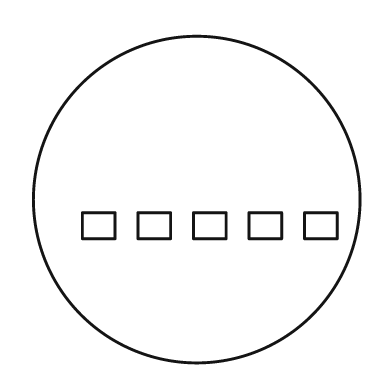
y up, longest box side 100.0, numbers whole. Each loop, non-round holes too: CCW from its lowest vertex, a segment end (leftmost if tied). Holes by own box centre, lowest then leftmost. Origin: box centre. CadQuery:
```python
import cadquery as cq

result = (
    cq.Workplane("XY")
    .moveTo(0.0, 0.0)
    .circle(50.0)
    .moveTo(-35.0, -12.0)
    .lineTo(-25.0, -12.0)
    .lineTo(-25.0, -4.0)
    .lineTo(-35.0, -4.0)
    .close()
    .moveTo(-18.0, -12.0)
    .lineTo(-8.0, -12.0)
    .lineTo(-8.0, -4.0)
    .lineTo(-18.0, -4.0)
    .close()
    .moveTo(-1.0, -12.0)
    .lineTo(9.0, -12.0)
    .lineTo(9.0, -4.0)
    .lineTo(-1.0, -4.0)
    .close()
    .moveTo(16.0, -12.0)
    .lineTo(26.0, -12.0)
    .lineTo(26.0, -4.0)
    .lineTo(16.0, -4.0)
    .close()
    .moveTo(33.0, -12.0)
    .lineTo(43.0, -12.0)
    .lineTo(43.0, -4.0)
    .lineTo(33.0, -4.0)
    .close()
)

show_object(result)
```